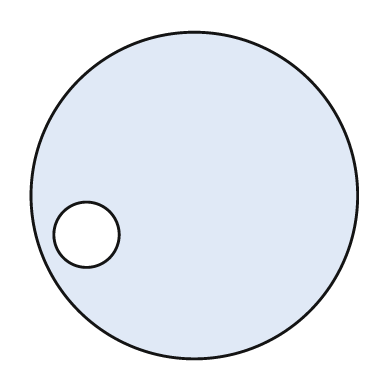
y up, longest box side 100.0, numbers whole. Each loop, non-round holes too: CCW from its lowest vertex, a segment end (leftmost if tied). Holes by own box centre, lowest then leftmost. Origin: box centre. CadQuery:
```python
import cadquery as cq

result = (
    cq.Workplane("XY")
    .moveTo(0.0, 0.0)
    .circle(50.0)
    .moveTo(-33.0, -12.0)
    .circle(10.0)
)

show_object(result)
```